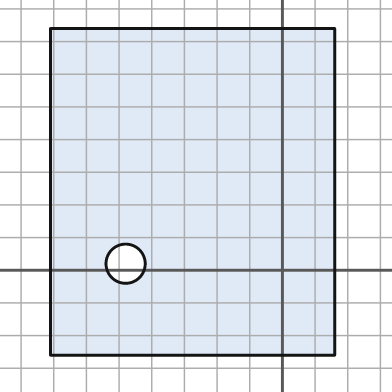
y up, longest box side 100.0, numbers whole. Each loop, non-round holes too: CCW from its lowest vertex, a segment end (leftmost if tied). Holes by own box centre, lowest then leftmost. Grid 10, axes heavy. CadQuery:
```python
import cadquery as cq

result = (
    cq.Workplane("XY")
    .moveTo(-71.0, -26.0)
    .lineTo(16.0, -26.0)
    .lineTo(16.0, 74.0)
    .lineTo(-71.0, 74.0)
    .close()
    .moveTo(-48.0, 2.0)
    .circle(6.0)
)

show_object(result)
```